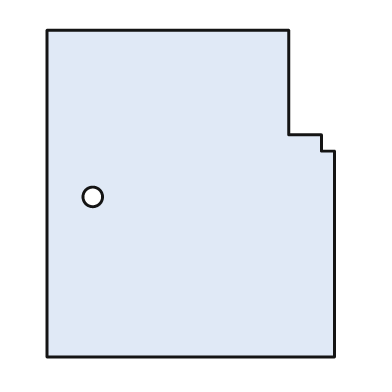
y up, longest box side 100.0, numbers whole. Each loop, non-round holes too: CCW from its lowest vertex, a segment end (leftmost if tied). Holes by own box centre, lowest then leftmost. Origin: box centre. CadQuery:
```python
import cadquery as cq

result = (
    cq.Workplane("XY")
    .moveTo(-44.0, -50.0)
    .lineTo(44.0, -50.0)
    .lineTo(44.0, 13.0)
    .lineTo(40.0, 13.0)
    .lineTo(40.0, 18.0)
    .lineTo(30.0, 18.0)
    .lineTo(30.0, 50.0)
    .lineTo(-44.0, 50.0)
    .close()
    .moveTo(-30.0, -1.0)
    .circle(3.0)
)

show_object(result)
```